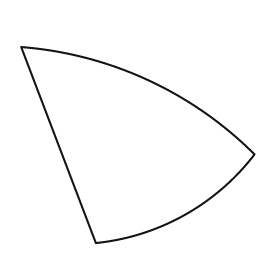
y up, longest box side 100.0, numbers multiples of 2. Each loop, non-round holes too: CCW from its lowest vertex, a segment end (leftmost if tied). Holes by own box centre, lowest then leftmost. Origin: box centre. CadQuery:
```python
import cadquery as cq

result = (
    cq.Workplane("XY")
    .moveTo(-18.0, -42.0)
    .threePointArc((20.0, -30.0), (50.0, -4.0))
    .threePointArc((4.0, 28.0), (-50.0, 42.0))
    .close()
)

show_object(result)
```